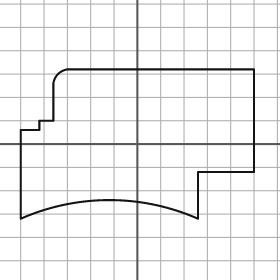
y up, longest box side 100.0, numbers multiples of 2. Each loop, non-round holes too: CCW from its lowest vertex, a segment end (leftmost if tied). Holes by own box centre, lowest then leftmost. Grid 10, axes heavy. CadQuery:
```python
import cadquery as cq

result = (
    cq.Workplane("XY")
    .moveTo(-50.0, -32.0)
    .threePointArc((-12.0, -24.0), (26.0, -32.0))
    .lineTo(26.0, -12.0)
    .lineTo(50.0, -12.0)
    .lineTo(50.0, 32.0)
    .lineTo(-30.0, 32.0)
    .threePointArc((-34.0, 30.0), (-36.0, 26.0))
    .lineTo(-36.0, 10.0)
    .lineTo(-42.0, 10.0)
    .lineTo(-42.0, 6.0)
    .lineTo(-50.0, 6.0)
    .close()
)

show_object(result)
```